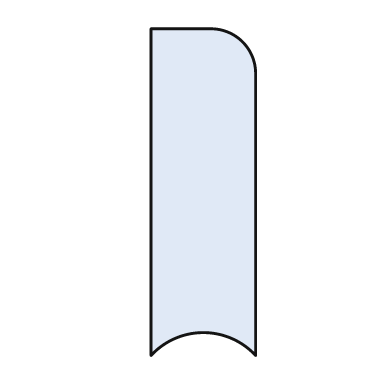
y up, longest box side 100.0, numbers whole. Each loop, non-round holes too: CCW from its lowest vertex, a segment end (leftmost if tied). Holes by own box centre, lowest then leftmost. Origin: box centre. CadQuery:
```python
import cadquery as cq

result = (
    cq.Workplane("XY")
    .moveTo(-16.0, -50.0)
    .threePointArc((0.0, -43.0), (16.0, -50.0))
    .lineTo(16.0, 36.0)
    .threePointArc((12.0, 46.0), (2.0, 50.0))
    .lineTo(-16.0, 50.0)
    .close()
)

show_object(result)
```